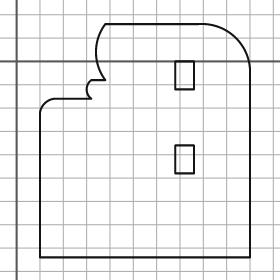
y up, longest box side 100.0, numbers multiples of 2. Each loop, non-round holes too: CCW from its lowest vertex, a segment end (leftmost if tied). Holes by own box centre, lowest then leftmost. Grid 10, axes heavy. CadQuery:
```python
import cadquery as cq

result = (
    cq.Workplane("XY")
    .moveTo(10.0, -84.0)
    .lineTo(100.0, -84.0)
    .lineTo(100.0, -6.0)
    .threePointArc((94.0, 10.0), (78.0, 16.0))
    .lineTo(38.0, 16.0)
    .threePointArc((34.0, 4.0), (38.0, -8.0))
    .lineTo(32.0, -8.0)
    .threePointArc((30.0, -12.0), (32.0, -16.0))
    .lineTo(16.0, -16.0)
    .threePointArc((12.0, -18.0), (10.0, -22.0))
    .close()
    .moveTo(68.0, -48.0)
    .lineTo(76.0, -48.0)
    .lineTo(76.0, -36.0)
    .lineTo(68.0, -36.0)
    .close()
    .moveTo(68.0, -12.0)
    .lineTo(76.0, -12.0)
    .lineTo(76.0, 0.0)
    .lineTo(68.0, 0.0)
    .close()
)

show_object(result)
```